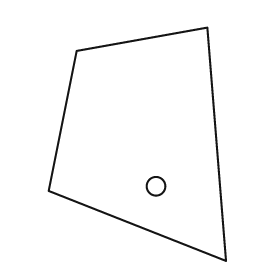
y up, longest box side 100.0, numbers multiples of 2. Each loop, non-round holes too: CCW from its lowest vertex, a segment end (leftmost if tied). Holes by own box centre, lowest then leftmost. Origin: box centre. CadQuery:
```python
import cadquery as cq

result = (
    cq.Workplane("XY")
    .moveTo(38.0, -50.0)
    .lineTo(30.0, 50.0)
    .lineTo(-26.0, 40.0)
    .lineTo(-38.0, -20.0)
    .close()
    .moveTo(8.0, -18.0)
    .circle(4.0)
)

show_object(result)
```